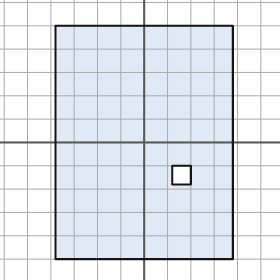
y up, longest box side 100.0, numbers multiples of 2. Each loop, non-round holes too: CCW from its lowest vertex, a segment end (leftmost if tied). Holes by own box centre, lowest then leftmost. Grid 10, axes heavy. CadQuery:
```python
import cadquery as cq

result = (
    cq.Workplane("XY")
    .moveTo(-38.0, -50.0)
    .lineTo(38.0, -50.0)
    .lineTo(38.0, 50.0)
    .lineTo(-38.0, 50.0)
    .close()
    .moveTo(12.0, -18.0)
    .lineTo(20.0, -18.0)
    .lineTo(20.0, -10.0)
    .lineTo(12.0, -10.0)
    .close()
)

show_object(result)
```